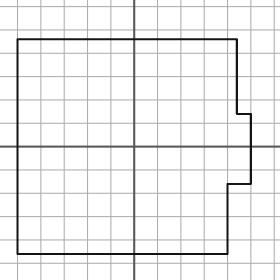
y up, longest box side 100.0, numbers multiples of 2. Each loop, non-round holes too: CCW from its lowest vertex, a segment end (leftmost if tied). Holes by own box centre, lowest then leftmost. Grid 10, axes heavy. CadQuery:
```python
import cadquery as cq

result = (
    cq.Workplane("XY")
    .moveTo(-50.0, -46.0)
    .lineTo(40.0, -46.0)
    .lineTo(40.0, -16.0)
    .lineTo(50.0, -16.0)
    .lineTo(50.0, 14.0)
    .lineTo(44.0, 14.0)
    .lineTo(44.0, 46.0)
    .lineTo(-50.0, 46.0)
    .close()
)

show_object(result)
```